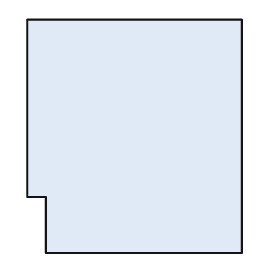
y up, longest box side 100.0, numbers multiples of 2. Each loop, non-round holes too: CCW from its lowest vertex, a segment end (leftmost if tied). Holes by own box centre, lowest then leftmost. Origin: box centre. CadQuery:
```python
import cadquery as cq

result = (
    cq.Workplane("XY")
    .moveTo(-38.0, -50.0)
    .lineTo(46.0, -50.0)
    .lineTo(46.0, 50.0)
    .lineTo(-46.0, 50.0)
    .lineTo(-46.0, -26.0)
    .lineTo(-38.0, -26.0)
    .close()
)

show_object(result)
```